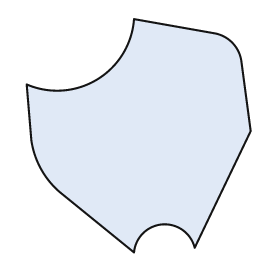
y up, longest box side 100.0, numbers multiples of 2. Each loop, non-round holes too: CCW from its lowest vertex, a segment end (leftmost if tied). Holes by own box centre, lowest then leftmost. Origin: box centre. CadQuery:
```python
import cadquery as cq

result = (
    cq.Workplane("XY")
    .moveTo(-2.0, -50.0)
    .threePointArc((10.0, -38.0), (24.0, -48.0))
    .lineTo(48.0, 2.0)
    .lineTo(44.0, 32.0)
    .threePointArc((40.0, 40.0), (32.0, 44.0))
    .lineTo(-2.0, 50.0)
    .threePointArc((-18.0, 24.0), (-48.0, 22.0))
    .lineTo(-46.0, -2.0)
    .threePointArc((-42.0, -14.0), (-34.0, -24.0))
    .close()
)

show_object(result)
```